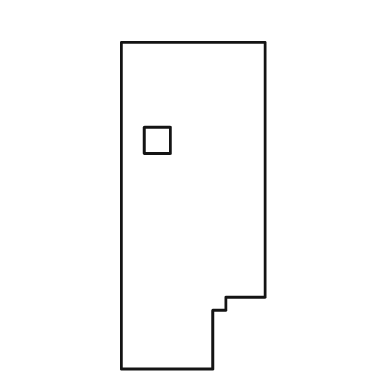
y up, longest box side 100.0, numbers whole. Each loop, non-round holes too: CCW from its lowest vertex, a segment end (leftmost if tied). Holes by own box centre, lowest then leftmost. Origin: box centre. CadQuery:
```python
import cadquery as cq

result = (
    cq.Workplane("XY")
    .moveTo(-22.0, -50.0)
    .lineTo(6.0, -50.0)
    .lineTo(6.0, -32.0)
    .lineTo(10.0, -32.0)
    .lineTo(10.0, -28.0)
    .lineTo(22.0, -28.0)
    .lineTo(22.0, 50.0)
    .lineTo(-22.0, 50.0)
    .close()
    .moveTo(-15.0, 16.0)
    .lineTo(-7.0, 16.0)
    .lineTo(-7.0, 24.0)
    .lineTo(-15.0, 24.0)
    .close()
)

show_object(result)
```